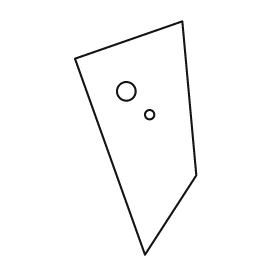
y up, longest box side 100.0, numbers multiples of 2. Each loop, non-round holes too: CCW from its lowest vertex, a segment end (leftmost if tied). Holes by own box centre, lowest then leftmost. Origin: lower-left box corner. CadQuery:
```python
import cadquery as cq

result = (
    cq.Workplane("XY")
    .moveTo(30.0, 0.0)
    .lineTo(52.0, 34.0)
    .lineTo(46.0, 100.0)
    .lineTo(0.0, 84.0)
    .close()
    .moveTo(32.0, 60.0)
    .circle(2.0)
    .moveTo(22.0, 70.0)
    .circle(4.0)
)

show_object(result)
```